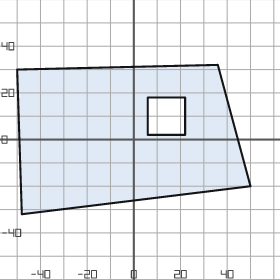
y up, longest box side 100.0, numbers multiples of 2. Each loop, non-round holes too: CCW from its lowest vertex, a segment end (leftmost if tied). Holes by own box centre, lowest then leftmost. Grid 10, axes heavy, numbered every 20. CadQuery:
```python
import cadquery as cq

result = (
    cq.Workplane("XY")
    .moveTo(-48.0, -32.0)
    .lineTo(50.0, -20.0)
    .lineTo(36.0, 32.0)
    .lineTo(-50.0, 30.0)
    .close()
    .moveTo(6.0, 2.0)
    .lineTo(22.0, 2.0)
    .lineTo(22.0, 18.0)
    .lineTo(6.0, 18.0)
    .close()
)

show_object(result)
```